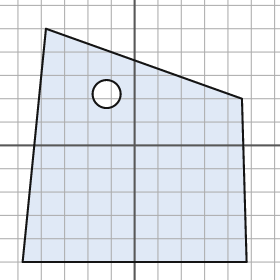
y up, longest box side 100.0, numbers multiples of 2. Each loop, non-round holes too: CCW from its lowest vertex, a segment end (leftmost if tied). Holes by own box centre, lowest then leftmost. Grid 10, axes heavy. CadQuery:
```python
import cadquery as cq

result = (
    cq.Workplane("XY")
    .moveTo(-48.0, -50.0)
    .lineTo(48.0, -50.0)
    .lineTo(46.0, 20.0)
    .lineTo(-38.0, 50.0)
    .close()
    .moveTo(-12.0, 22.0)
    .circle(6.0)
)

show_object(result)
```